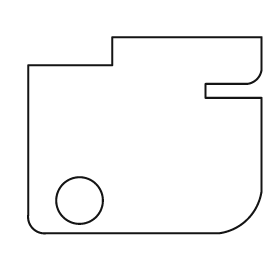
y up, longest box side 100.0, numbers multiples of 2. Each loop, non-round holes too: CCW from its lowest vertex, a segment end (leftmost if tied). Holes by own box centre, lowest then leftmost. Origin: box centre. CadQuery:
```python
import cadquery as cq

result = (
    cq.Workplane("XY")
    .moveTo(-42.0, -42.0)
    .lineTo(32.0, -42.0)
    .threePointArc((44.0, -36.0), (50.0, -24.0))
    .lineTo(50.0, 16.0)
    .lineTo(26.0, 16.0)
    .lineTo(26.0, 22.0)
    .lineTo(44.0, 22.0)
    .threePointArc((48.0, 24.0), (50.0, 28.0))
    .lineTo(50.0, 42.0)
    .lineTo(-14.0, 42.0)
    .lineTo(-14.0, 30.0)
    .lineTo(-50.0, 30.0)
    .lineTo(-50.0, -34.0)
    .threePointArc((-48.0, -40.0), (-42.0, -42.0))
    .close()
    .moveTo(-28.0, -28.0)
    .circle(10.0)
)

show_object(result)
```